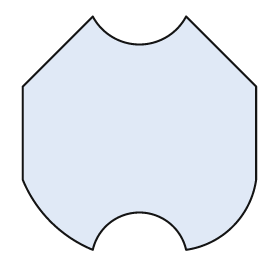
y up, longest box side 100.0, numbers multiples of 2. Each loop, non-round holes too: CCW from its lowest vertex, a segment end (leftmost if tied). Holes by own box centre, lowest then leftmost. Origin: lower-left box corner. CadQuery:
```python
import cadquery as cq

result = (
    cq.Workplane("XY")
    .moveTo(30.0, 0.0)
    .threePointArc((50.0, 16.0), (70.0, 0.0))
    .threePointArc((90.0, 10.0), (100.0, 30.0))
    .lineTo(100.0, 70.0)
    .lineTo(70.0, 100.0)
    .threePointArc((50.0, 88.0), (30.0, 100.0))
    .lineTo(0.0, 70.0)
    .lineTo(0.0, 30.0)
    .threePointArc((12.0, 12.0), (30.0, 0.0))
    .close()
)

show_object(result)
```